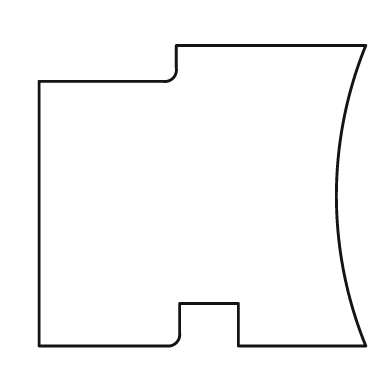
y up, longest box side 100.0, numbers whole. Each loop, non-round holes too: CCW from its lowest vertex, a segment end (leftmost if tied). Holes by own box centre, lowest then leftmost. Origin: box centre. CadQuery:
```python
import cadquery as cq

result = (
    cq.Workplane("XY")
    .moveTo(-50.0, -46.0)
    .lineTo(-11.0, -46.0)
    .threePointArc((-8.0, -45.0), (-7.0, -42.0))
    .lineTo(-7.0, -33.0)
    .lineTo(11.0, -33.0)
    .lineTo(11.0, -46.0)
    .lineTo(50.0, -46.0)
    .threePointArc((41.0, 0.0), (50.0, 46.0))
    .lineTo(-8.0, 46.0)
    .lineTo(-8.0, 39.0)
    .threePointArc((-9.0, 36.0), (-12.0, 35.0))
    .lineTo(-50.0, 35.0)
    .close()
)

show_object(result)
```